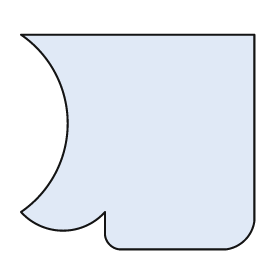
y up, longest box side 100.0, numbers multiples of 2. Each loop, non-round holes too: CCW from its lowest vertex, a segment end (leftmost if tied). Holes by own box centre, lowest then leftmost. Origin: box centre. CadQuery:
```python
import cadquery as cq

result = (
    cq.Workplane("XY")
    .moveTo(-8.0, -46.0)
    .lineTo(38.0, -46.0)
    .threePointArc((46.0, -42.0), (50.0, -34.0))
    .lineTo(50.0, 46.0)
    .lineTo(-50.0, 46.0)
    .threePointArc((-30.0, 8.0), (-50.0, -30.0))
    .threePointArc((-32.0, -38.0), (-14.0, -30.0))
    .lineTo(-14.0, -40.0)
    .threePointArc((-12.0, -44.0), (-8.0, -46.0))
    .close()
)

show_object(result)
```